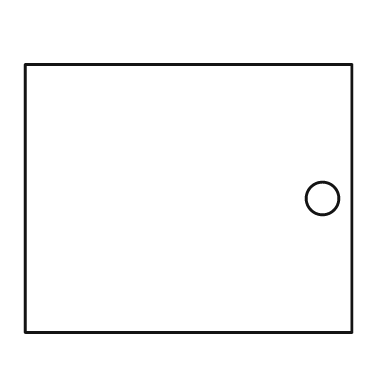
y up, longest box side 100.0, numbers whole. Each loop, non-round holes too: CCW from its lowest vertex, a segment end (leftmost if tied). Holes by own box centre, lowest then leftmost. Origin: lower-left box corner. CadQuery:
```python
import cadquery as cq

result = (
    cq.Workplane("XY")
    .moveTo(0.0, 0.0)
    .lineTo(100.0, 0.0)
    .lineTo(100.0, 82.0)
    .lineTo(0.0, 82.0)
    .close()
    .moveTo(91.0, 41.0)
    .circle(5.0)
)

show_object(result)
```